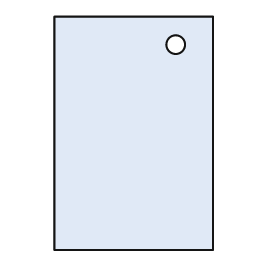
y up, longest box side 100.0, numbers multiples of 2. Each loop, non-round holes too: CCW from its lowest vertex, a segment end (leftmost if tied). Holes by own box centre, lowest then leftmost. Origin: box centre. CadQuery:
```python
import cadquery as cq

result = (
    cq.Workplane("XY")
    .moveTo(-34.0, -50.0)
    .lineTo(34.0, -50.0)
    .lineTo(34.0, 50.0)
    .lineTo(-34.0, 50.0)
    .close()
    .moveTo(18.0, 38.0)
    .circle(4.0)
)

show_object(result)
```